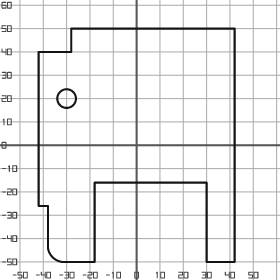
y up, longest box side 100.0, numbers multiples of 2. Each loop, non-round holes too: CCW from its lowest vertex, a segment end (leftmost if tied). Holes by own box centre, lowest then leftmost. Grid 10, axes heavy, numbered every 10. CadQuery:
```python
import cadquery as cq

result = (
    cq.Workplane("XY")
    .moveTo(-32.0, -50.0)
    .lineTo(-18.0, -50.0)
    .lineTo(-18.0, -16.0)
    .lineTo(30.0, -16.0)
    .lineTo(30.0, -50.0)
    .lineTo(42.0, -50.0)
    .lineTo(42.0, 50.0)
    .lineTo(-28.0, 50.0)
    .lineTo(-28.0, 40.0)
    .lineTo(-42.0, 40.0)
    .lineTo(-42.0, -26.0)
    .lineTo(-38.0, -26.0)
    .lineTo(-38.0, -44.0)
    .threePointArc((-36.0, -48.0), (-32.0, -50.0))
    .close()
    .moveTo(-30.0, 20.0)
    .circle(4.0)
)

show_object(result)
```